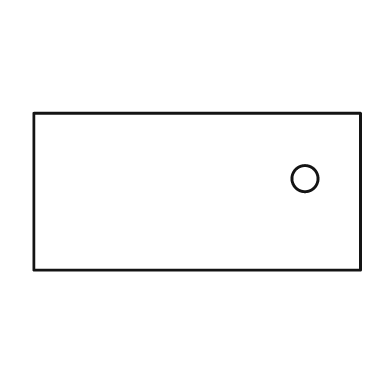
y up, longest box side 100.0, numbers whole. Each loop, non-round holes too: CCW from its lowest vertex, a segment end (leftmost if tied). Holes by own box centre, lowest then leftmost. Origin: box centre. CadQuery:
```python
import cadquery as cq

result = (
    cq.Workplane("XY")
    .moveTo(-50.0, -24.0)
    .lineTo(50.0, -24.0)
    .lineTo(50.0, 24.0)
    .lineTo(-50.0, 24.0)
    .close()
    .moveTo(33.0, 4.0)
    .circle(4.0)
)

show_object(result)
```